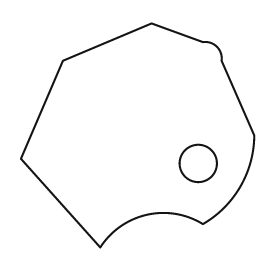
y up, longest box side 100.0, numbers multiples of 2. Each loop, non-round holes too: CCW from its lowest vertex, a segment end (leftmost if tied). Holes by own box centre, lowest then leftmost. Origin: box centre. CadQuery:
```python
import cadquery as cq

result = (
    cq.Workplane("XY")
    .moveTo(-16.0, -48.0)
    .threePointArc((4.0, -34.0), (28.0, -38.0))
    .threePointArc((44.0, -22.0), (50.0, 0.0))
    .lineTo(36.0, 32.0)
    .threePointArc((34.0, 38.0), (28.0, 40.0))
    .lineTo(6.0, 48.0)
    .lineTo(-32.0, 32.0)
    .lineTo(-50.0, -10.0)
    .close()
    .moveTo(26.0, -12.0)
    .circle(8.0)
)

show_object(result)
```